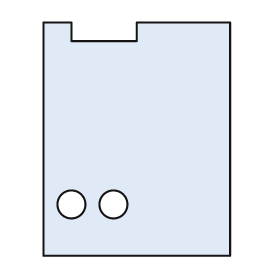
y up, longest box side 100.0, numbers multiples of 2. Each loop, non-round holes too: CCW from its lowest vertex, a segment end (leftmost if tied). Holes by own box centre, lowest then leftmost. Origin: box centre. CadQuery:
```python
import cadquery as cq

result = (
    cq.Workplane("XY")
    .moveTo(-40.0, -50.0)
    .lineTo(40.0, -50.0)
    .lineTo(40.0, 50.0)
    .lineTo(0.0, 50.0)
    .lineTo(0.0, 42.0)
    .lineTo(-28.0, 42.0)
    .lineTo(-28.0, 50.0)
    .lineTo(-40.0, 50.0)
    .close()
    .moveTo(-28.0, -28.0)
    .circle(6.0)
    .moveTo(-10.0, -28.0)
    .circle(6.0)
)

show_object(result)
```